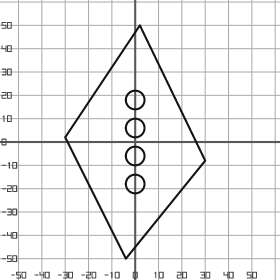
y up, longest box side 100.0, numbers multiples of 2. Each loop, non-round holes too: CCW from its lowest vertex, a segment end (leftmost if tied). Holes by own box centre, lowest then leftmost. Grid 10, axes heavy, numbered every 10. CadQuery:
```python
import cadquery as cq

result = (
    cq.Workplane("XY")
    .moveTo(-4.0, -50.0)
    .lineTo(30.0, -8.0)
    .lineTo(2.0, 50.0)
    .lineTo(-30.0, 2.0)
    .close()
    .moveTo(0.0, -18.0)
    .circle(4.0)
    .moveTo(0.0, -6.0)
    .circle(4.0)
    .moveTo(0.0, 6.0)
    .circle(4.0)
    .moveTo(0.0, 18.0)
    .circle(4.0)
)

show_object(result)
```